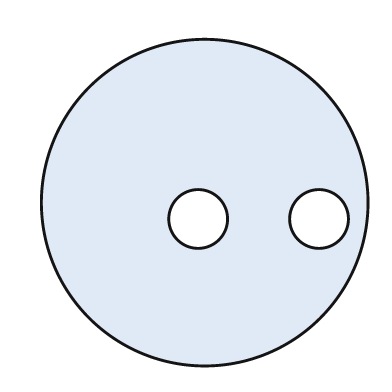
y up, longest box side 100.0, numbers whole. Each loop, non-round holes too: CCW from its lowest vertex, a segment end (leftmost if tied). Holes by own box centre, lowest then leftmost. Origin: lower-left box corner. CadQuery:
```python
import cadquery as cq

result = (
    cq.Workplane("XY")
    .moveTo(50.0, 50.0)
    .circle(50.0)
    .moveTo(48.0, 45.0)
    .circle(9.0)
    .moveTo(85.0, 45.0)
    .circle(9.0)
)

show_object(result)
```